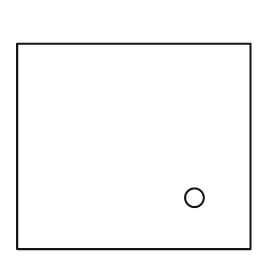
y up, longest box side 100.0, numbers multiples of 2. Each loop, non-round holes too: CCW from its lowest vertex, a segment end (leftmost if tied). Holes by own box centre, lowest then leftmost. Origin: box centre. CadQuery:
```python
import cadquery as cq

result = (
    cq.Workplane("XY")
    .moveTo(-50.0, -44.0)
    .lineTo(50.0, -44.0)
    .lineTo(50.0, 44.0)
    .lineTo(-50.0, 44.0)
    .close()
    .moveTo(26.0, -22.0)
    .circle(4.0)
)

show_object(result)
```